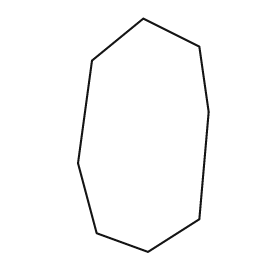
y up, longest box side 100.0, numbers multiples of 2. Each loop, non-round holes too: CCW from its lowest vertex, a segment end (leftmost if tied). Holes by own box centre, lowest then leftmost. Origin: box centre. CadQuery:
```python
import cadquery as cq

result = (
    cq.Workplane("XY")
    .moveTo(2.0, -50.0)
    .lineTo(24.0, -36.0)
    .lineTo(28.0, 10.0)
    .lineTo(24.0, 38.0)
    .lineTo(0.0, 50.0)
    .lineTo(-22.0, 32.0)
    .lineTo(-28.0, -12.0)
    .lineTo(-20.0, -42.0)
    .close()
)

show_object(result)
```